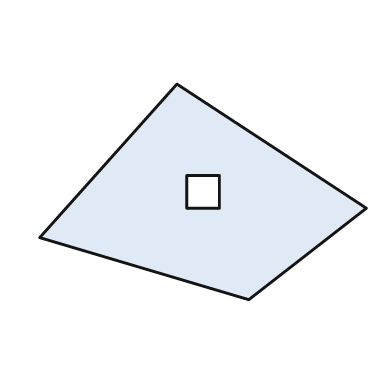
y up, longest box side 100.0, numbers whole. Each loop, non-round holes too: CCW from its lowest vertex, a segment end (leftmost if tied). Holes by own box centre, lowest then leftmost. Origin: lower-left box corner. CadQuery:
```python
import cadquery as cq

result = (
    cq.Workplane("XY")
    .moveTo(64.0, 0.0)
    .lineTo(100.0, 28.0)
    .lineTo(42.0, 66.0)
    .lineTo(0.0, 19.0)
    .close()
    .moveTo(45.0, 28.0)
    .lineTo(55.0, 28.0)
    .lineTo(55.0, 38.0)
    .lineTo(45.0, 38.0)
    .close()
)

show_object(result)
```